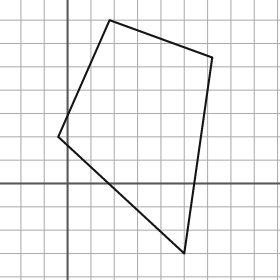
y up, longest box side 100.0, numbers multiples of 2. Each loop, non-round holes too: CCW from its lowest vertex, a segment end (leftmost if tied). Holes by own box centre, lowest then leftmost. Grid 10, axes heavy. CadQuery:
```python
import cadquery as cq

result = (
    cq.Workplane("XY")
    .moveTo(50.0, -30.0)
    .lineTo(62.0, 54.0)
    .lineTo(18.0, 70.0)
    .lineTo(-4.0, 20.0)
    .close()
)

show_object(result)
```